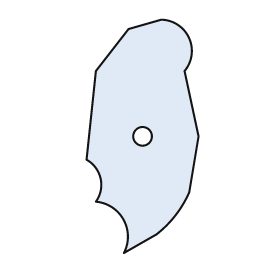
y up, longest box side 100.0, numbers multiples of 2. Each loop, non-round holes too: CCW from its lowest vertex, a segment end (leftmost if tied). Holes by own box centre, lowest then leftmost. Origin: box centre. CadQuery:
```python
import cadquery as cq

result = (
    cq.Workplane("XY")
    .moveTo(-8.0, -50.0)
    .lineTo(6.0, -42.0)
    .threePointArc((14.0, -34.0), (20.0, -24.0))
    .lineTo(24.0, 0.0)
    .lineTo(18.0, 28.0)
    .threePointArc((20.0, 42.0), (8.0, 50.0))
    .lineTo(-6.0, 46.0)
    .lineTo(-20.0, 28.0)
    .lineTo(-24.0, -10.0)
    .threePointArc((-18.0, -18.0), (-20.0, -28.0))
    .threePointArc((-8.0, -36.0), (-8.0, -50.0))
    .close()
    .moveTo(0.0, 0.0)
    .circle(4.0)
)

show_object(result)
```